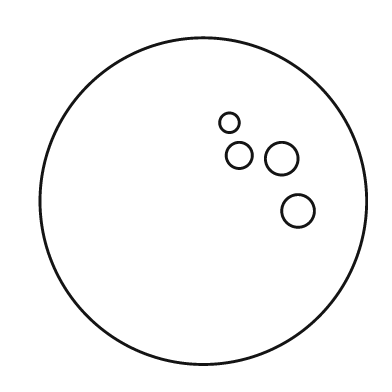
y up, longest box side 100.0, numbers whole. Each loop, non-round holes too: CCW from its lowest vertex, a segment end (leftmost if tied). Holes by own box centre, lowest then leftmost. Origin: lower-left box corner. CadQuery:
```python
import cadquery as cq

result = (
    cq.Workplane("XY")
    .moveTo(50.0, 50.0)
    .circle(50.0)
    .moveTo(79.0, 47.0)
    .circle(5.0)
    .moveTo(74.0, 63.0)
    .circle(5.0)
    .moveTo(61.0, 64.0)
    .circle(4.0)
    .moveTo(58.0, 74.0)
    .circle(3.0)
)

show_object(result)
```